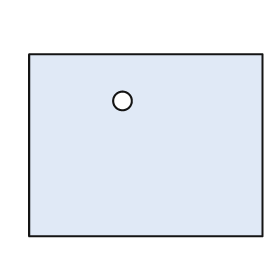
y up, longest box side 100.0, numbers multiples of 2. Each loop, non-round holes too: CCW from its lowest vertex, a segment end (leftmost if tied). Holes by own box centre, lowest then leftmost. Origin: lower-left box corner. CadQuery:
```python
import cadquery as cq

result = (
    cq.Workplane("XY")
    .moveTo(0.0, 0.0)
    .lineTo(100.0, 0.0)
    .lineTo(100.0, 78.0)
    .lineTo(0.0, 78.0)
    .close()
    .moveTo(40.0, 58.0)
    .circle(4.0)
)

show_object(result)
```